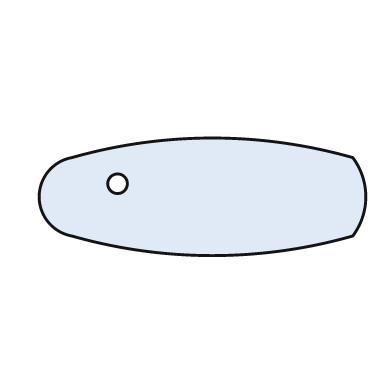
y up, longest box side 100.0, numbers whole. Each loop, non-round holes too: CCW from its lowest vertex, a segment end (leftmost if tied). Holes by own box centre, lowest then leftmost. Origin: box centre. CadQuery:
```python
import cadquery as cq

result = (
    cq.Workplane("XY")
    .moveTo(-40.0, -12.0)
    .threePointArc((3.0, -18.0), (46.0, -12.0))
    .threePointArc((50.0, 0.0), (46.0, 12.0))
    .threePointArc((3.0, 18.0), (-40.0, 12.0))
    .threePointArc((-50.0, 0.0), (-40.0, -12.0))
    .close()
    .moveTo(-26.0, 4.0)
    .circle(3.0)
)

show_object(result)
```